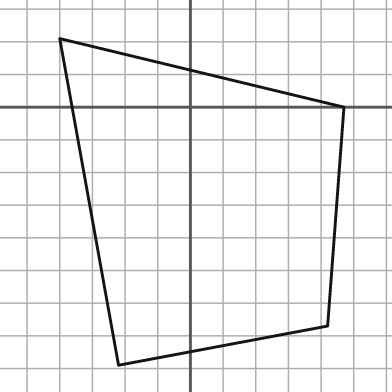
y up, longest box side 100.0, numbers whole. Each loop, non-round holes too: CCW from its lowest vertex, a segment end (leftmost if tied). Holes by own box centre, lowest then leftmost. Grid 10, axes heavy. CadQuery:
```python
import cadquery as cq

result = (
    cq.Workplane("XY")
    .moveTo(-22.0, -79.0)
    .lineTo(42.0, -67.0)
    .lineTo(47.0, 0.0)
    .lineTo(-40.0, 21.0)
    .close()
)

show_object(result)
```